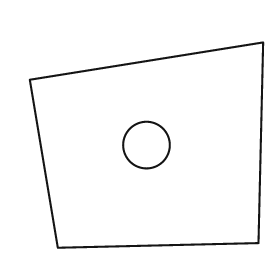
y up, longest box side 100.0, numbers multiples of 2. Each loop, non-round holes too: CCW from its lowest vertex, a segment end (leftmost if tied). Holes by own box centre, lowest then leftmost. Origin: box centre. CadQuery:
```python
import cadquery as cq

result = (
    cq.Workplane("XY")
    .moveTo(-38.0, -44.0)
    .lineTo(48.0, -42.0)
    .lineTo(50.0, 44.0)
    .lineTo(-50.0, 28.0)
    .close()
    .moveTo(0.0, 0.0)
    .circle(10.0)
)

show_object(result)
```